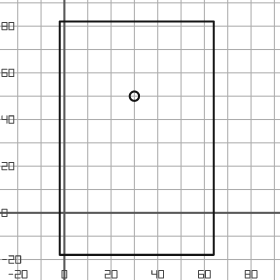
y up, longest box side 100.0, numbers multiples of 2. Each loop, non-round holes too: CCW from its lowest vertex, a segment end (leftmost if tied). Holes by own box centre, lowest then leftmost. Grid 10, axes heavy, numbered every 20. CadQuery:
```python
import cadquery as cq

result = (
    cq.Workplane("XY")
    .moveTo(-2.0, -18.0)
    .lineTo(64.0, -18.0)
    .lineTo(64.0, 82.0)
    .lineTo(-2.0, 82.0)
    .close()
    .moveTo(30.0, 50.0)
    .circle(2.0)
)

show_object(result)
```